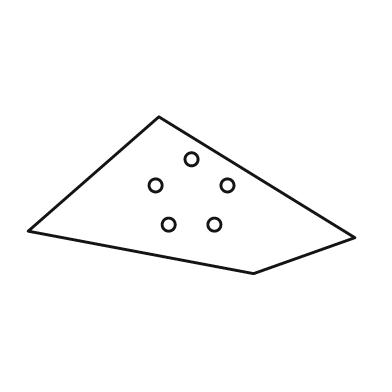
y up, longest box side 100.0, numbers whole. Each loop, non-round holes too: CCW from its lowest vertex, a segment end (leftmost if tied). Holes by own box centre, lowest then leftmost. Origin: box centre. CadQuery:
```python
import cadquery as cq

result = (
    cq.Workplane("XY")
    .moveTo(19.0, -24.0)
    .lineTo(50.0, -13.0)
    .lineTo(-10.0, 24.0)
    .lineTo(-50.0, -11.0)
    .close()
    .moveTo(-7.0, -9.0)
    .circle(2.0)
    .moveTo(7.0, -9.0)
    .circle(2.0)
    .moveTo(-11.0, 3.0)
    .circle(2.0)
    .moveTo(11.0, 3.0)
    .circle(2.0)
    .moveTo(0.0, 11.0)
    .circle(2.0)
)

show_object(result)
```